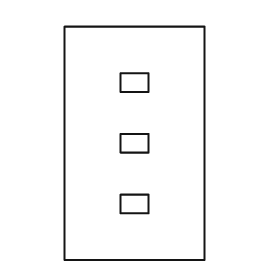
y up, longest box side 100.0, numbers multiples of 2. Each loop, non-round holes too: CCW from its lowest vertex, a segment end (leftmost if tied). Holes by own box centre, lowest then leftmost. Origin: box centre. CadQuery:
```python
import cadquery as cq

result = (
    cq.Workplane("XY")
    .moveTo(-30.0, -50.0)
    .lineTo(30.0, -50.0)
    .lineTo(30.0, 50.0)
    .lineTo(-30.0, 50.0)
    .close()
    .moveTo(-6.0, -30.0)
    .lineTo(6.0, -30.0)
    .lineTo(6.0, -22.0)
    .lineTo(-6.0, -22.0)
    .close()
    .moveTo(-6.0, -4.0)
    .lineTo(6.0, -4.0)
    .lineTo(6.0, 4.0)
    .lineTo(-6.0, 4.0)
    .close()
    .moveTo(-6.0, 22.0)
    .lineTo(6.0, 22.0)
    .lineTo(6.0, 30.0)
    .lineTo(-6.0, 30.0)
    .close()
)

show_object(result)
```